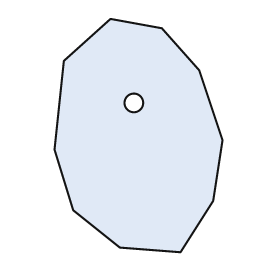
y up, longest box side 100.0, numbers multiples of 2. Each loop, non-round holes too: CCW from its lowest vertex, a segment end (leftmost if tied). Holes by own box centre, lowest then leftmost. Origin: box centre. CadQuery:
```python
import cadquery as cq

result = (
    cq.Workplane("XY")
    .moveTo(18.0, -50.0)
    .lineTo(32.0, -28.0)
    .lineTo(36.0, -2.0)
    .lineTo(26.0, 28.0)
    .lineTo(10.0, 46.0)
    .lineTo(-12.0, 50.0)
    .lineTo(-32.0, 32.0)
    .lineTo(-36.0, -6.0)
    .lineTo(-28.0, -32.0)
    .lineTo(-8.0, -48.0)
    .close()
    .moveTo(-2.0, 14.0)
    .circle(4.0)
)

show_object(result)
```